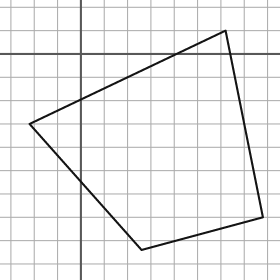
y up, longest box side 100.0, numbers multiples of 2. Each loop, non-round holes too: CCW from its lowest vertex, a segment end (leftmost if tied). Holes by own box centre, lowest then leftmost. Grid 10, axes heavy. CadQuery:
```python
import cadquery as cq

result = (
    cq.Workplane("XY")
    .moveTo(26.0, -84.0)
    .lineTo(78.0, -70.0)
    .lineTo(62.0, 10.0)
    .lineTo(-22.0, -30.0)
    .close()
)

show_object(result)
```